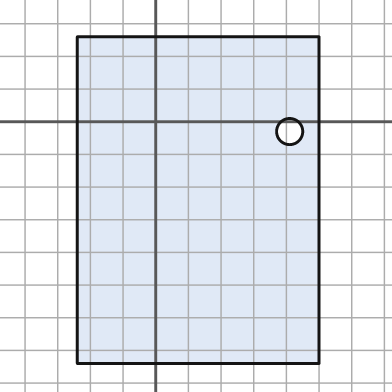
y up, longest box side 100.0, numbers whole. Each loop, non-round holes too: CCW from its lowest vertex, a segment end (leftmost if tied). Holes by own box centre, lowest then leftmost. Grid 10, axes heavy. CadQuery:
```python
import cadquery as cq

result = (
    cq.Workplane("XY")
    .moveTo(-24.0, -74.0)
    .lineTo(50.0, -74.0)
    .lineTo(50.0, 26.0)
    .lineTo(-24.0, 26.0)
    .close()
    .moveTo(41.0, -3.0)
    .circle(4.0)
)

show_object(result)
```